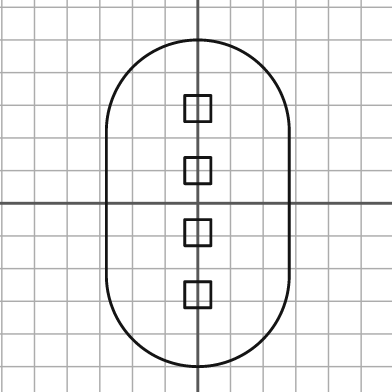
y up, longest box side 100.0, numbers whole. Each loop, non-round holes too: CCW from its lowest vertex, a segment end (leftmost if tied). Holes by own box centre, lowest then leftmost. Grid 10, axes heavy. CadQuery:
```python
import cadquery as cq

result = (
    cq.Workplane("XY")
    .moveTo(-28.0, -22.0)
    .threePointArc((0.0, -50.0), (28.0, -22.0))
    .lineTo(28.0, 22.0)
    .threePointArc((0.0, 50.0), (-28.0, 22.0))
    .close()
    .moveTo(-4.0, -32.0)
    .lineTo(4.0, -32.0)
    .lineTo(4.0, -24.0)
    .lineTo(-4.0, -24.0)
    .close()
    .moveTo(-4.0, -13.0)
    .lineTo(4.0, -13.0)
    .lineTo(4.0, -5.0)
    .lineTo(-4.0, -5.0)
    .close()
    .moveTo(-4.0, 6.0)
    .lineTo(4.0, 6.0)
    .lineTo(4.0, 14.0)
    .lineTo(-4.0, 14.0)
    .close()
    .moveTo(-4.0, 25.0)
    .lineTo(4.0, 25.0)
    .lineTo(4.0, 33.0)
    .lineTo(-4.0, 33.0)
    .close()
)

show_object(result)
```